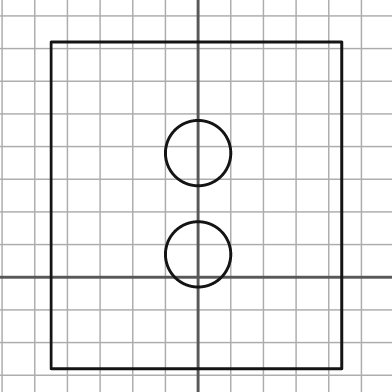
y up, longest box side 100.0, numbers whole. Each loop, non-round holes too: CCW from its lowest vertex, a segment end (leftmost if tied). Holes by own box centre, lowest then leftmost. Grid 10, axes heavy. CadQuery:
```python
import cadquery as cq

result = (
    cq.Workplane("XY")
    .moveTo(-45.0, -28.0)
    .lineTo(44.0, -28.0)
    .lineTo(44.0, 72.0)
    .lineTo(-45.0, 72.0)
    .close()
    .moveTo(0.0, 7.0)
    .circle(10.0)
    .moveTo(0.0, 38.0)
    .circle(10.0)
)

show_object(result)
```